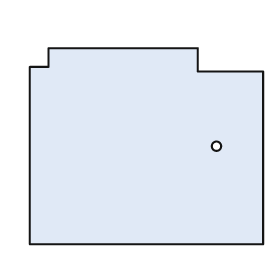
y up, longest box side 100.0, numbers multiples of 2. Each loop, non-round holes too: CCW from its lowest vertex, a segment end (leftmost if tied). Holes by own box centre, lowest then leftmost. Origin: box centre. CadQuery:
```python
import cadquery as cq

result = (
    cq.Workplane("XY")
    .moveTo(-50.0, -42.0)
    .lineTo(50.0, -42.0)
    .lineTo(50.0, 32.0)
    .lineTo(22.0, 32.0)
    .lineTo(22.0, 42.0)
    .lineTo(-42.0, 42.0)
    .lineTo(-42.0, 34.0)
    .lineTo(-50.0, 34.0)
    .close()
    .moveTo(30.0, 0.0)
    .circle(2.0)
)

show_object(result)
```